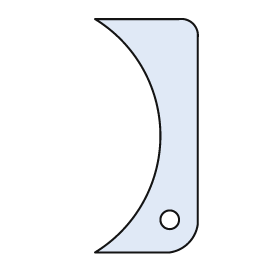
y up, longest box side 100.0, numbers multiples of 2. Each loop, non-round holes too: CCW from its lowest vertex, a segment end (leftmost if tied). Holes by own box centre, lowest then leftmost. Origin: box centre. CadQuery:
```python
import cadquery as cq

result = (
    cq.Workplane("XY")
    .moveTo(-22.0, -50.0)
    .lineTo(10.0, -50.0)
    .threePointArc((18.0, -46.0), (22.0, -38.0))
    .lineTo(22.0, 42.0)
    .threePointArc((20.0, 48.0), (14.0, 50.0))
    .lineTo(-22.0, 50.0)
    .threePointArc((6.0, 0.0), (-22.0, -50.0))
    .close()
    .moveTo(10.0, -36.0)
    .circle(4.0)
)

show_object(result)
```